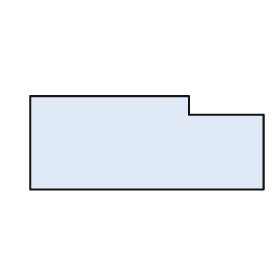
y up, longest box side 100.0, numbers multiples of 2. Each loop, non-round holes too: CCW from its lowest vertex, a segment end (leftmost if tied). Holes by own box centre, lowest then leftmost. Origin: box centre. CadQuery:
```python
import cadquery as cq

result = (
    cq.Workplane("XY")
    .moveTo(-50.0, -20.0)
    .lineTo(50.0, -20.0)
    .lineTo(50.0, 12.0)
    .lineTo(18.0, 12.0)
    .lineTo(18.0, 20.0)
    .lineTo(-50.0, 20.0)
    .close()
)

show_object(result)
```